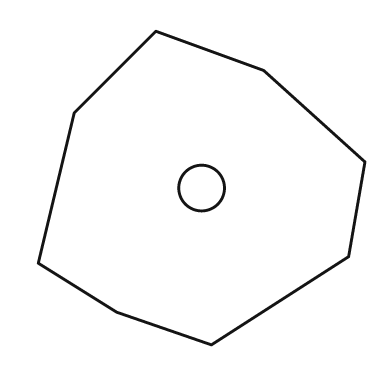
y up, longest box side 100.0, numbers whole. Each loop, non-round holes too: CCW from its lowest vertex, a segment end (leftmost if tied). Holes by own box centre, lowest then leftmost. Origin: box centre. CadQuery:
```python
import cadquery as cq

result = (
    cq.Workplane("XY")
    .moveTo(3.0, -48.0)
    .lineTo(45.0, -21.0)
    .lineTo(50.0, 8.0)
    .lineTo(19.0, 36.0)
    .lineTo(-14.0, 48.0)
    .lineTo(-39.0, 23.0)
    .lineTo(-50.0, -23.0)
    .lineTo(-26.0, -38.0)
    .close()
    .moveTo(0.0, 0.0)
    .circle(7.0)
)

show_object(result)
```